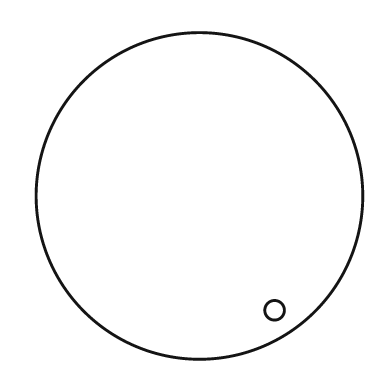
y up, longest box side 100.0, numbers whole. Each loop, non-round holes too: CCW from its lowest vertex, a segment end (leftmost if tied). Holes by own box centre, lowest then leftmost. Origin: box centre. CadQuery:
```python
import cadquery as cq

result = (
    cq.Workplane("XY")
    .moveTo(0.0, 0.0)
    .circle(50.0)
    .moveTo(23.0, -35.0)
    .circle(3.0)
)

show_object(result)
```